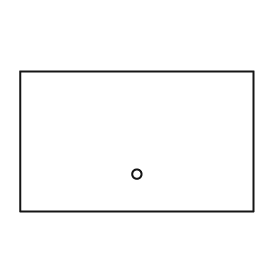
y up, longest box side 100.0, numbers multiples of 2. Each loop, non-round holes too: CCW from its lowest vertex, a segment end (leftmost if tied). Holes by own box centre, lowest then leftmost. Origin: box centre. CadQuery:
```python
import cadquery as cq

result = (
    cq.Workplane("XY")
    .moveTo(-50.0, -30.0)
    .lineTo(50.0, -30.0)
    .lineTo(50.0, 30.0)
    .lineTo(-50.0, 30.0)
    .close()
    .moveTo(0.0, -14.0)
    .circle(2.0)
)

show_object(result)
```